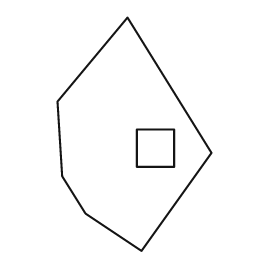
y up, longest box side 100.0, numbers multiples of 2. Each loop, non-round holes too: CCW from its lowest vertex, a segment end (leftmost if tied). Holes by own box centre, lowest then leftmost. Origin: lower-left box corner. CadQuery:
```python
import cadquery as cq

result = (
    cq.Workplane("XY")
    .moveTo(36.0, 0.0)
    .lineTo(66.0, 42.0)
    .lineTo(30.0, 100.0)
    .lineTo(0.0, 64.0)
    .lineTo(2.0, 32.0)
    .lineTo(12.0, 16.0)
    .close()
    .moveTo(34.0, 36.0)
    .lineTo(50.0, 36.0)
    .lineTo(50.0, 52.0)
    .lineTo(34.0, 52.0)
    .close()
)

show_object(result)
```